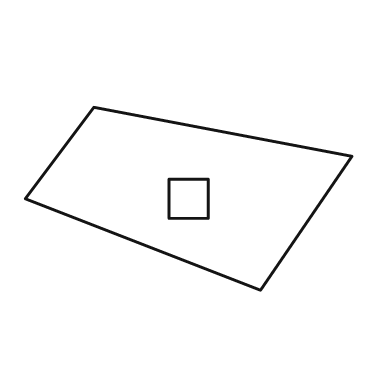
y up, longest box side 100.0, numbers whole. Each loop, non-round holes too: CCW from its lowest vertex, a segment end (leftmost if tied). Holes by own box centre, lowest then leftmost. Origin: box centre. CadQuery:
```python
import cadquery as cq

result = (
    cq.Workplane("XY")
    .moveTo(22.0, -28.0)
    .lineTo(50.0, 13.0)
    .lineTo(-29.0, 28.0)
    .lineTo(-50.0, 0.0)
    .close()
    .moveTo(-6.0, -6.0)
    .lineTo(6.0, -6.0)
    .lineTo(6.0, 6.0)
    .lineTo(-6.0, 6.0)
    .close()
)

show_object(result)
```